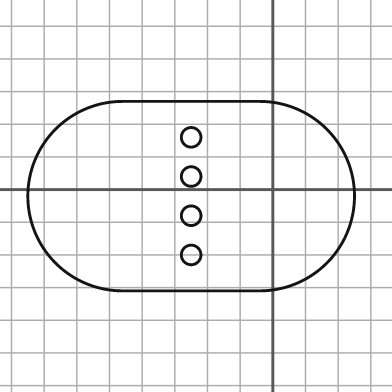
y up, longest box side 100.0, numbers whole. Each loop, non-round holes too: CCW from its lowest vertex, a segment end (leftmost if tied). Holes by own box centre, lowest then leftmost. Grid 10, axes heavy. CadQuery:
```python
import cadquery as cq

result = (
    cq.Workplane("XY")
    .moveTo(-46.0, -31.0)
    .lineTo(-4.0, -31.0)
    .threePointArc((25.0, -2.0), (-4.0, 27.0))
    .lineTo(-46.0, 27.0)
    .threePointArc((-75.0, -2.0), (-46.0, -31.0))
    .close()
    .moveTo(-25.0, -20.0)
    .circle(3.0)
    .moveTo(-25.0, -8.0)
    .circle(3.0)
    .moveTo(-25.0, 4.0)
    .circle(3.0)
    .moveTo(-25.0, 16.0)
    .circle(3.0)
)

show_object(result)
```